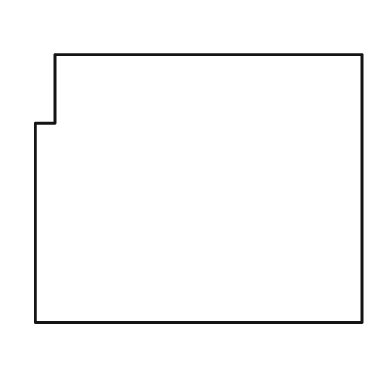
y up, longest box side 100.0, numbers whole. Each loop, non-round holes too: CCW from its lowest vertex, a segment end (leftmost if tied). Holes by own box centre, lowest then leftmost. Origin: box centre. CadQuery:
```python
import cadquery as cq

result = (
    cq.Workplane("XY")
    .moveTo(-50.0, -41.0)
    .lineTo(50.0, -41.0)
    .lineTo(50.0, 41.0)
    .lineTo(-44.0, 41.0)
    .lineTo(-44.0, 20.0)
    .lineTo(-50.0, 20.0)
    .close()
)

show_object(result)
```